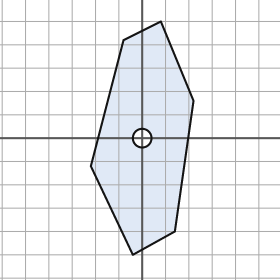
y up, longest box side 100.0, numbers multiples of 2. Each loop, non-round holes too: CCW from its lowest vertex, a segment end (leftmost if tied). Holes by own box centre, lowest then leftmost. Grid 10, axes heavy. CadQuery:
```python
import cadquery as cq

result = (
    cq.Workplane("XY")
    .moveTo(-4.0, -50.0)
    .lineTo(14.0, -40.0)
    .lineTo(22.0, 16.0)
    .lineTo(8.0, 50.0)
    .lineTo(-8.0, 42.0)
    .lineTo(-22.0, -12.0)
    .close()
    .moveTo(0.0, 0.0)
    .circle(4.0)
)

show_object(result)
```